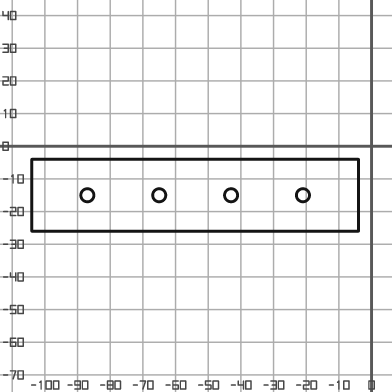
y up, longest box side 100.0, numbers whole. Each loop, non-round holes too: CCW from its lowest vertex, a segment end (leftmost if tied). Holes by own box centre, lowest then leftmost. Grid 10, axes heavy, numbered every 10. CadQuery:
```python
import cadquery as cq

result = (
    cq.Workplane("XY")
    .moveTo(-104.0, -26.0)
    .lineTo(-4.0, -26.0)
    .lineTo(-4.0, -4.0)
    .lineTo(-104.0, -4.0)
    .close()
    .moveTo(-87.0, -15.0)
    .circle(2.0)
    .moveTo(-65.0, -15.0)
    .circle(2.0)
    .moveTo(-43.0, -15.0)
    .circle(2.0)
    .moveTo(-21.0, -15.0)
    .circle(2.0)
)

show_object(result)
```